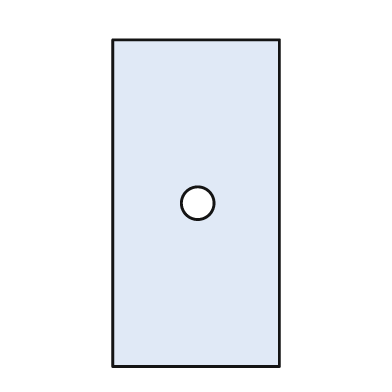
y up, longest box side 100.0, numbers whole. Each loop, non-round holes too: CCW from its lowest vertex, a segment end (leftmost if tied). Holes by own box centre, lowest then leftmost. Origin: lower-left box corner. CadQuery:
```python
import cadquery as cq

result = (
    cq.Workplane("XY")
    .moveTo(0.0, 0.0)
    .lineTo(51.0, 0.0)
    .lineTo(51.0, 100.0)
    .lineTo(0.0, 100.0)
    .close()
    .moveTo(26.0, 50.0)
    .circle(5.0)
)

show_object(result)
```